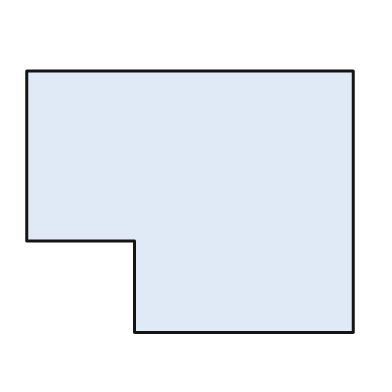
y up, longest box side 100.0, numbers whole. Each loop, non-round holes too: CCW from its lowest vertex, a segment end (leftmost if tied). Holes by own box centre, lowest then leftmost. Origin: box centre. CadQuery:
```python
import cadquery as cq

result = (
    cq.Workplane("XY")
    .moveTo(-17.0, -40.0)
    .lineTo(50.0, -40.0)
    .lineTo(50.0, 40.0)
    .lineTo(-50.0, 40.0)
    .lineTo(-50.0, -12.0)
    .lineTo(-17.0, -12.0)
    .close()
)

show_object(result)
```